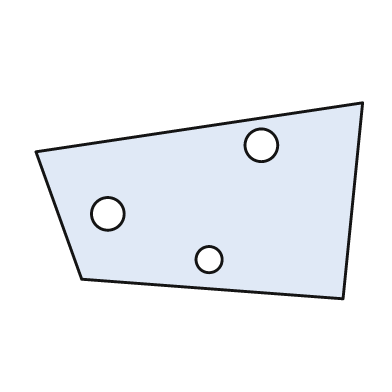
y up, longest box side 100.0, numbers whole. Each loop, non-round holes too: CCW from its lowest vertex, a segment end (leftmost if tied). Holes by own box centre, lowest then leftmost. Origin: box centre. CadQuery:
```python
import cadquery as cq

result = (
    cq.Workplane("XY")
    .moveTo(44.0, -30.0)
    .lineTo(50.0, 30.0)
    .lineTo(-50.0, 15.0)
    .lineTo(-36.0, -24.0)
    .close()
    .moveTo(3.0, -18.0)
    .circle(4.0)
    .moveTo(-28.0, -4.0)
    .circle(5.0)
    .moveTo(19.0, 17.0)
    .circle(5.0)
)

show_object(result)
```